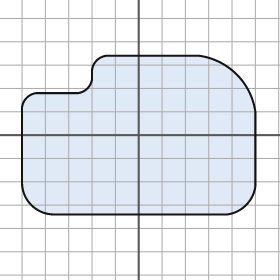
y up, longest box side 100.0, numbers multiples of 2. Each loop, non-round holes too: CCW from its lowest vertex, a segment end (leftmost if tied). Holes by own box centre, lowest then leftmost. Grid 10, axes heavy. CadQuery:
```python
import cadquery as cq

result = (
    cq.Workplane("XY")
    .moveTo(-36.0, -34.0)
    .lineTo(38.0, -34.0)
    .threePointArc((46.0, -30.0), (50.0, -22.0))
    .lineTo(50.0, 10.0)
    .threePointArc((42.0, 26.0), (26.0, 34.0))
    .lineTo(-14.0, 34.0)
    .threePointArc((-18.0, 32.0), (-20.0, 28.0))
    .lineTo(-20.0, 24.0)
    .threePointArc((-22.0, 20.0), (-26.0, 18.0))
    .lineTo(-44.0, 18.0)
    .threePointArc((-48.0, 16.0), (-50.0, 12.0))
    .lineTo(-50.0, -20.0)
    .threePointArc((-46.0, -30.0), (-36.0, -34.0))
    .close()
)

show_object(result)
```